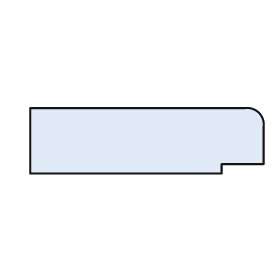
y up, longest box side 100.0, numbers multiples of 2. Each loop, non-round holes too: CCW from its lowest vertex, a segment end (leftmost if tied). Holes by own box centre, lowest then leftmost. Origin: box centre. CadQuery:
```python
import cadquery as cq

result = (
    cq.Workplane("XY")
    .moveTo(-50.0, -14.0)
    .lineTo(32.0, -14.0)
    .lineTo(32.0, -10.0)
    .lineTo(50.0, -10.0)
    .lineTo(50.0, 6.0)
    .threePointArc((48.0, 12.0), (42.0, 14.0))
    .lineTo(-50.0, 14.0)
    .close()
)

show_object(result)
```